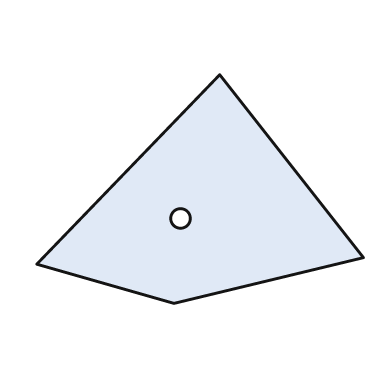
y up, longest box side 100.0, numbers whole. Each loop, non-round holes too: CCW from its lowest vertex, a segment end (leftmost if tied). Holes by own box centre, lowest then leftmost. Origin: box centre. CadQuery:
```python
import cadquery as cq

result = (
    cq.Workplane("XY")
    .moveTo(-8.0, -35.0)
    .lineTo(50.0, -21.0)
    .lineTo(6.0, 35.0)
    .lineTo(-50.0, -23.0)
    .close()
    .moveTo(-6.0, -9.0)
    .circle(3.0)
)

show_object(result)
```